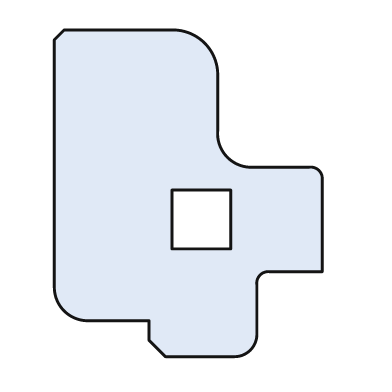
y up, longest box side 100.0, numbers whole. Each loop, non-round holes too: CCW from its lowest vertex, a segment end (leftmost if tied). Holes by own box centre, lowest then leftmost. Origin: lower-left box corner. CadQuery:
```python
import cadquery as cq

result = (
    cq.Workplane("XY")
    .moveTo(34.0, 0.0)
    .lineTo(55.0, 0.0)
    .threePointArc((60.0, 2.0), (62.0, 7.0))
    .lineTo(62.0, 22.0)
    .threePointArc((63.0, 25.0), (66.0, 26.0))
    .lineTo(82.0, 26.0)
    .lineTo(82.0, 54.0)
    .threePointArc((81.0, 57.0), (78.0, 58.0))
    .lineTo(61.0, 58.0)
    .threePointArc((53.0, 61.0), (50.0, 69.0))
    .lineTo(50.0, 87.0)
    .threePointArc((46.0, 96.0), (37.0, 100.0))
    .lineTo(3.0, 100.0)
    .lineTo(0.0, 97.0)
    .lineTo(0.0, 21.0)
    .threePointArc((3.0, 14.0), (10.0, 11.0))
    .lineTo(29.0, 11.0)
    .lineTo(29.0, 5.0)
    .close()
    .moveTo(36.0, 33.0)
    .lineTo(54.0, 33.0)
    .lineTo(54.0, 51.0)
    .lineTo(36.0, 51.0)
    .close()
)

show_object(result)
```